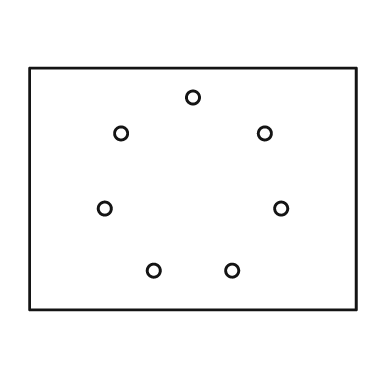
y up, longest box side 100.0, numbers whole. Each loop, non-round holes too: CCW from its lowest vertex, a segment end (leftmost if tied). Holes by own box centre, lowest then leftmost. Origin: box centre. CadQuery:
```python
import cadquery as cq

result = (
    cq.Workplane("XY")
    .moveTo(-50.0, -37.0)
    .lineTo(50.0, -37.0)
    .lineTo(50.0, 37.0)
    .lineTo(-50.0, 37.0)
    .close()
    .moveTo(-12.0, -25.0)
    .circle(2.0)
    .moveTo(12.0, -25.0)
    .circle(2.0)
    .moveTo(-27.0, -6.0)
    .circle(2.0)
    .moveTo(27.0, -6.0)
    .circle(2.0)
    .moveTo(-22.0, 17.0)
    .circle(2.0)
    .moveTo(22.0, 17.0)
    .circle(2.0)
    .moveTo(0.0, 28.0)
    .circle(2.0)
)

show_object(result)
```